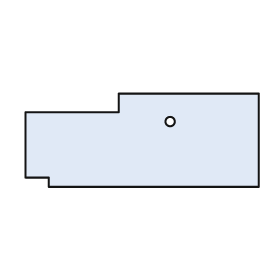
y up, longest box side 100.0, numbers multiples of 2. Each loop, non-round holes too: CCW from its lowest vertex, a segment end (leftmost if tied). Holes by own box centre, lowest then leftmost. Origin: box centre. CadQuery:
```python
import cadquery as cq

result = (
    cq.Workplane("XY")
    .moveTo(-40.0, -20.0)
    .lineTo(50.0, -20.0)
    .lineTo(50.0, 20.0)
    .lineTo(-10.0, 20.0)
    .lineTo(-10.0, 12.0)
    .lineTo(-50.0, 12.0)
    .lineTo(-50.0, -16.0)
    .lineTo(-40.0, -16.0)
    .close()
    .moveTo(12.0, 8.0)
    .circle(2.0)
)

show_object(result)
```